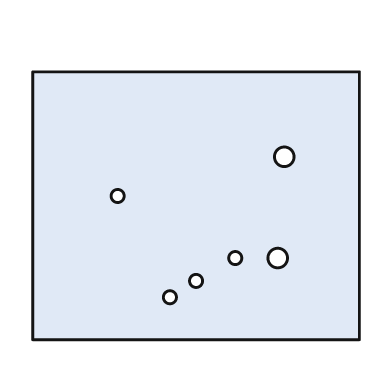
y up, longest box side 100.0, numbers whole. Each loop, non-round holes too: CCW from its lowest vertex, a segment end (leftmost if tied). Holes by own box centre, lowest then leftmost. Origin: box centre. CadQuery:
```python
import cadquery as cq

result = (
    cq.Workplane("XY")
    .moveTo(-50.0, -41.0)
    .lineTo(50.0, -41.0)
    .lineTo(50.0, 41.0)
    .lineTo(-50.0, 41.0)
    .close()
    .moveTo(-8.0, -28.0)
    .circle(2.0)
    .moveTo(0.0, -23.0)
    .circle(2.0)
    .moveTo(12.0, -16.0)
    .circle(2.0)
    .moveTo(25.0, -16.0)
    .circle(3.0)
    .moveTo(-24.0, 3.0)
    .circle(2.0)
    .moveTo(27.0, 15.0)
    .circle(3.0)
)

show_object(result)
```